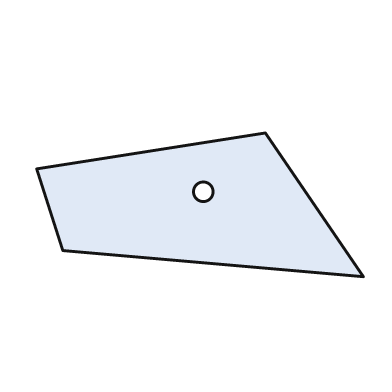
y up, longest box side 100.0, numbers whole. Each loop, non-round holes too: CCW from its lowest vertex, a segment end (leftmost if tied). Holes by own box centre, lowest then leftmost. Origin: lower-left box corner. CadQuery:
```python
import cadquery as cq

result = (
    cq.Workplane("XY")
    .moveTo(100.0, 0.0)
    .lineTo(70.0, 44.0)
    .lineTo(0.0, 33.0)
    .lineTo(8.0, 8.0)
    .close()
    .moveTo(51.0, 26.0)
    .circle(3.0)
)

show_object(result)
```